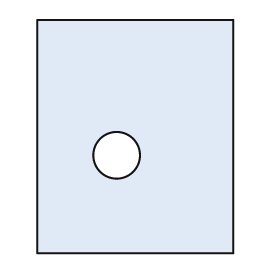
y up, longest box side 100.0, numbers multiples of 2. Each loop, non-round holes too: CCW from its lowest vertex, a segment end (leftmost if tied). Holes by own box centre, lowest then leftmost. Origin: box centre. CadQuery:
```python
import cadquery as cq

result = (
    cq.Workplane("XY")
    .moveTo(-42.0, -50.0)
    .lineTo(42.0, -50.0)
    .lineTo(42.0, 50.0)
    .lineTo(-42.0, 50.0)
    .close()
    .moveTo(-8.0, -8.0)
    .circle(10.0)
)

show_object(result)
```